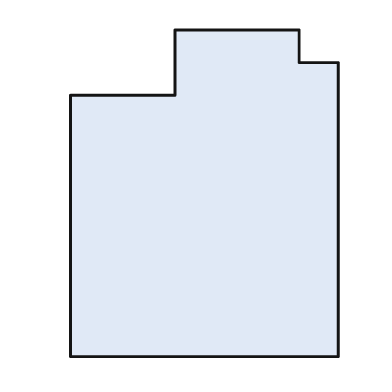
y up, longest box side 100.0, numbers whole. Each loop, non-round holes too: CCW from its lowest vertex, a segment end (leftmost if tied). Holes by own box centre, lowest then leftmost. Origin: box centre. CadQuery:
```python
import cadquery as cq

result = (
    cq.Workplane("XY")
    .moveTo(-41.0, -50.0)
    .lineTo(41.0, -50.0)
    .lineTo(41.0, 40.0)
    .lineTo(29.0, 40.0)
    .lineTo(29.0, 50.0)
    .lineTo(-9.0, 50.0)
    .lineTo(-9.0, 30.0)
    .lineTo(-41.0, 30.0)
    .close()
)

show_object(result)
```